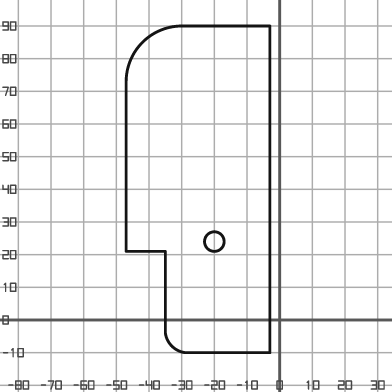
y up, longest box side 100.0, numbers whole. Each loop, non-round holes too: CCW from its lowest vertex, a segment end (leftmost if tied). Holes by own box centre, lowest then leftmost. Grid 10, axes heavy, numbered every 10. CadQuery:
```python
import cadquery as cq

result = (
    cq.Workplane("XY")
    .moveTo(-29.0, -10.0)
    .lineTo(-3.0, -10.0)
    .lineTo(-3.0, 90.0)
    .lineTo(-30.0, 90.0)
    .threePointArc((-42.0, 85.0), (-47.0, 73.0))
    .lineTo(-47.0, 21.0)
    .lineTo(-35.0, 21.0)
    .lineTo(-35.0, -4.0)
    .threePointArc((-33.0, -8.0), (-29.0, -10.0))
    .close()
    .moveTo(-20.0, 24.0)
    .circle(3.0)
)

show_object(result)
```